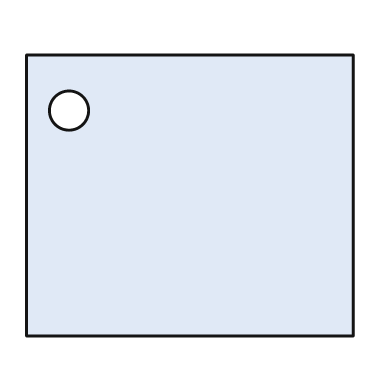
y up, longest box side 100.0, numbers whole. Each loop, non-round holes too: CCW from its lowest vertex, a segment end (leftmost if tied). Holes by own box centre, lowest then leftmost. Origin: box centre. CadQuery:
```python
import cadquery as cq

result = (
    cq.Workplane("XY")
    .moveTo(-50.0, -43.0)
    .lineTo(50.0, -43.0)
    .lineTo(50.0, 43.0)
    .lineTo(-50.0, 43.0)
    .close()
    .moveTo(-37.0, 26.0)
    .circle(6.0)
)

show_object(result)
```